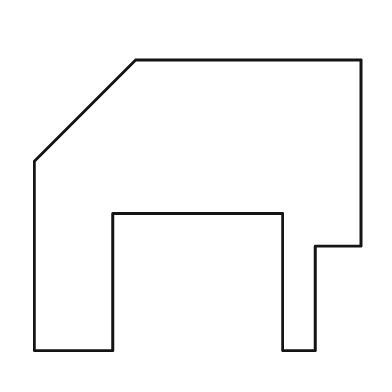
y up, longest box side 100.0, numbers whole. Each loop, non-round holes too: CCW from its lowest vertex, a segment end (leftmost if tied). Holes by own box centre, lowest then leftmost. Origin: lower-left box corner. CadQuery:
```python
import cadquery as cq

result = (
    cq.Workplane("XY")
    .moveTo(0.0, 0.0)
    .lineTo(24.0, 0.0)
    .lineTo(24.0, 42.0)
    .lineTo(76.0, 42.0)
    .lineTo(76.0, 0.0)
    .lineTo(86.0, 0.0)
    .lineTo(86.0, 32.0)
    .lineTo(100.0, 32.0)
    .lineTo(100.0, 89.0)
    .lineTo(31.0, 89.0)
    .lineTo(0.0, 58.0)
    .close()
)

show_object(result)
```